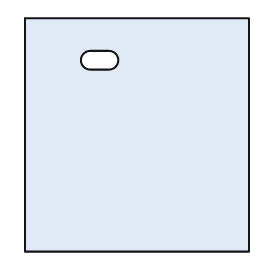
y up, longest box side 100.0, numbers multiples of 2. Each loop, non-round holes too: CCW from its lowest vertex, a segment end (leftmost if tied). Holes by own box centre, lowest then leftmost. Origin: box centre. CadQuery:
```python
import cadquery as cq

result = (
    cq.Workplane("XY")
    .moveTo(-48.0, -50.0)
    .lineTo(48.0, -50.0)
    .lineTo(48.0, 50.0)
    .lineTo(-48.0, 50.0)
    .close()
    .moveTo(-20.0, 28.0)
    .lineTo(-12.0, 28.0)
    .threePointArc((-8.0, 32.0), (-12.0, 36.0))
    .lineTo(-20.0, 36.0)
    .threePointArc((-24.0, 32.0), (-20.0, 28.0))
    .close()
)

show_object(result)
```